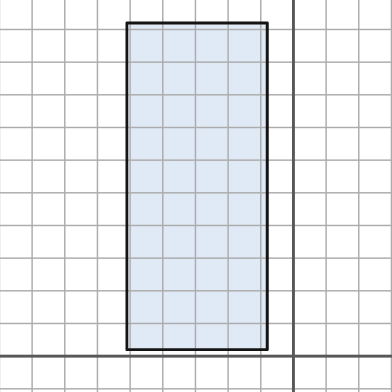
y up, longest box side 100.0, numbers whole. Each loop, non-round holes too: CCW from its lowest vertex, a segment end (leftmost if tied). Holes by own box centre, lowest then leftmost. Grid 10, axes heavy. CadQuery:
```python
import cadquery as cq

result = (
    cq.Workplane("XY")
    .moveTo(-51.0, 2.0)
    .lineTo(-8.0, 2.0)
    .lineTo(-8.0, 102.0)
    .lineTo(-51.0, 102.0)
    .close()
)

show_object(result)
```